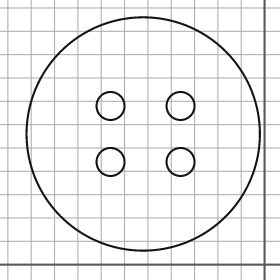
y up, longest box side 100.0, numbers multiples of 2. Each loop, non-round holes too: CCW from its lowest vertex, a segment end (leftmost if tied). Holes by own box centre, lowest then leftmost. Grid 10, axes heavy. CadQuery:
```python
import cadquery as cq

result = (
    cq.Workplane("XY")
    .moveTo(-52.0, 56.0)
    .circle(50.0)
    .moveTo(-66.0, 44.0)
    .circle(6.0)
    .moveTo(-36.0, 44.0)
    .circle(6.0)
    .moveTo(-66.0, 68.0)
    .circle(6.0)
    .moveTo(-36.0, 68.0)
    .circle(6.0)
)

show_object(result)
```